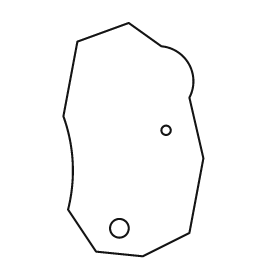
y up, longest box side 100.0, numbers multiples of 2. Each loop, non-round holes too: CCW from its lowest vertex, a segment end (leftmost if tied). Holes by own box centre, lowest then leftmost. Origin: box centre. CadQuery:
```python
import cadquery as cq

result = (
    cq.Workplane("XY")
    .moveTo(4.0, -50.0)
    .lineTo(24.0, -40.0)
    .lineTo(30.0, -8.0)
    .lineTo(24.0, 18.0)
    .threePointArc((24.0, 32.0), (12.0, 40.0))
    .lineTo(-2.0, 50.0)
    .lineTo(-24.0, 42.0)
    .lineTo(-30.0, 10.0)
    .threePointArc((-26.0, -10.0), (-28.0, -30.0))
    .lineTo(-16.0, -48.0)
    .close()
    .moveTo(-6.0, -38.0)
    .circle(4.0)
    .moveTo(14.0, 4.0)
    .circle(2.0)
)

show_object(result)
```